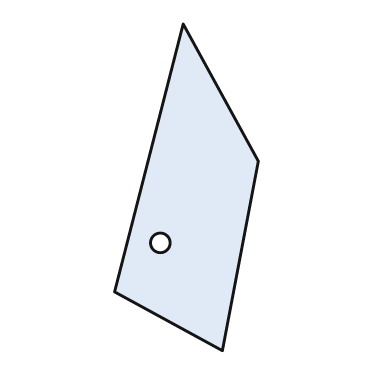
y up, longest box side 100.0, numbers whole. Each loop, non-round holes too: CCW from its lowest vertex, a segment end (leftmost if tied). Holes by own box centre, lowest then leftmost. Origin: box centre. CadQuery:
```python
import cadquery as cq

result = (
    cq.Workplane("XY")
    .moveTo(11.0, -50.0)
    .lineTo(22.0, 8.0)
    .lineTo(-1.0, 50.0)
    .lineTo(-22.0, -32.0)
    .close()
    .moveTo(-8.0, -17.0)
    .circle(3.0)
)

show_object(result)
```